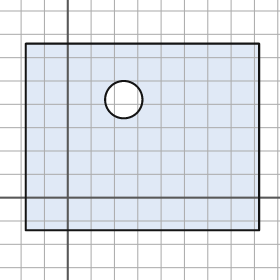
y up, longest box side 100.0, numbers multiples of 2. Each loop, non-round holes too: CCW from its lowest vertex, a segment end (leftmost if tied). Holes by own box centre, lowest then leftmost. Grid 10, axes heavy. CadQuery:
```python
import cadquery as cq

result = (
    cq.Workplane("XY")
    .moveTo(-18.0, -14.0)
    .lineTo(82.0, -14.0)
    .lineTo(82.0, 66.0)
    .lineTo(-18.0, 66.0)
    .close()
    .moveTo(24.0, 42.0)
    .circle(8.0)
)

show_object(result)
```